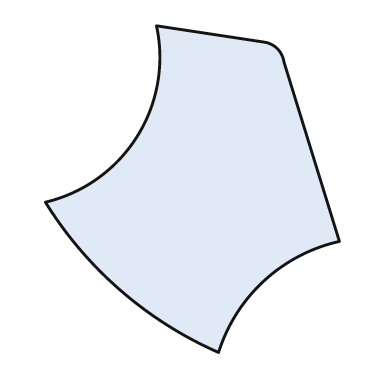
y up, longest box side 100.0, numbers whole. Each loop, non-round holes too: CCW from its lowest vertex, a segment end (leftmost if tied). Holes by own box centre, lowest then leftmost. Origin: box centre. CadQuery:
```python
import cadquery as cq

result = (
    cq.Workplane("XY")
    .moveTo(8.0, -50.0)
    .threePointArc((22.0, -28.0), (45.0, -16.0))
    .lineTo(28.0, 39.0)
    .threePointArc((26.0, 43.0), (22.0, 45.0))
    .lineTo(-11.0, 50.0)
    .threePointArc((-17.0, 16.0), (-45.0, -4.0))
    .threePointArc((-22.0, -31.0), (8.0, -50.0))
    .close()
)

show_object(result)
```